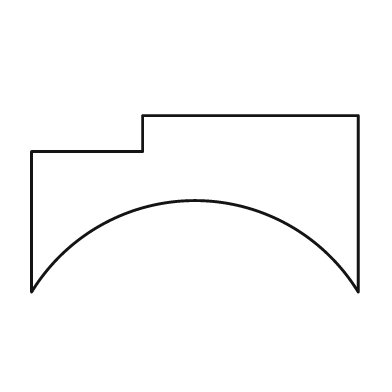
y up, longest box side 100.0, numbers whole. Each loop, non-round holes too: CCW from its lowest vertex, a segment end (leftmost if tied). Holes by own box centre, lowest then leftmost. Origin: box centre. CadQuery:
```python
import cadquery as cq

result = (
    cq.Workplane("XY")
    .moveTo(-50.0, -27.0)
    .threePointArc((0.0, 1.0), (50.0, -27.0))
    .lineTo(50.0, 27.0)
    .lineTo(-16.0, 27.0)
    .lineTo(-16.0, 16.0)
    .lineTo(-50.0, 16.0)
    .close()
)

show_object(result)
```